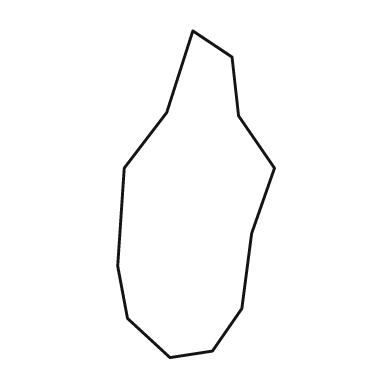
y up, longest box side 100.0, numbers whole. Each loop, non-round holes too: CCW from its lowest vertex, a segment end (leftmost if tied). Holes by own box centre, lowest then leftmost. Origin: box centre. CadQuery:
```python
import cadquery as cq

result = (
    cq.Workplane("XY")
    .moveTo(-8.0, -50.0)
    .lineTo(5.0, -48.0)
    .lineTo(14.0, -35.0)
    .lineTo(17.0, -12.0)
    .lineTo(24.0, 8.0)
    .lineTo(13.0, 24.0)
    .lineTo(11.0, 42.0)
    .lineTo(-1.0, 50.0)
    .lineTo(-9.0, 25.0)
    .lineTo(-22.0, 8.0)
    .lineTo(-24.0, -22.0)
    .lineTo(-21.0, -38.0)
    .close()
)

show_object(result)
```